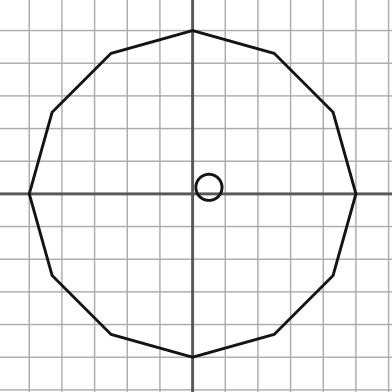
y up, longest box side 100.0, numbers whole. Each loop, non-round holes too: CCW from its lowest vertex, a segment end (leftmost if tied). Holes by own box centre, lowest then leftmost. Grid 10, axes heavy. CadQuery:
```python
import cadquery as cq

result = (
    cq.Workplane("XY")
    .moveTo(0.0, -50.0)
    .lineTo(25.0, -43.0)
    .lineTo(43.0, -25.0)
    .lineTo(50.0, 0.0)
    .lineTo(43.0, 25.0)
    .lineTo(25.0, 43.0)
    .lineTo(0.0, 50.0)
    .lineTo(-25.0, 43.0)
    .lineTo(-43.0, 25.0)
    .lineTo(-50.0, 0.0)
    .lineTo(-43.0, -25.0)
    .lineTo(-25.0, -43.0)
    .close()
    .moveTo(5.0, 2.0)
    .circle(4.0)
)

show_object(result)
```